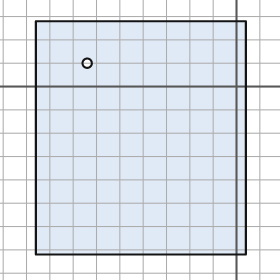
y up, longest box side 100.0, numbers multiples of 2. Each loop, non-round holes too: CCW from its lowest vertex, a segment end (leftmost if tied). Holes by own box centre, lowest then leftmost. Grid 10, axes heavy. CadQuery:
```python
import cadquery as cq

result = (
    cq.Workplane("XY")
    .moveTo(-86.0, -72.0)
    .lineTo(4.0, -72.0)
    .lineTo(4.0, 28.0)
    .lineTo(-86.0, 28.0)
    .close()
    .moveTo(-64.0, 10.0)
    .circle(2.0)
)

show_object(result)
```